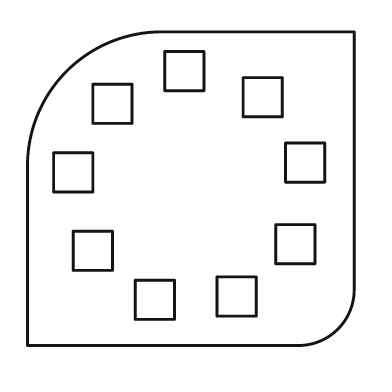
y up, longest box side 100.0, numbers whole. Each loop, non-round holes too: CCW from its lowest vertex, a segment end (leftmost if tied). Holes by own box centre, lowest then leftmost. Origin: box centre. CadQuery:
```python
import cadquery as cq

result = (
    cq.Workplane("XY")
    .moveTo(-50.0, -48.0)
    .lineTo(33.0, -48.0)
    .threePointArc((45.0, -43.0), (50.0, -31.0))
    .lineTo(50.0, 48.0)
    .lineTo(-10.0, 48.0)
    .threePointArc((-38.0, 36.0), (-50.0, 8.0))
    .close()
    .moveTo(-17.0, -40.0)
    .lineTo(-5.0, -40.0)
    .lineTo(-5.0, -28.0)
    .lineTo(-17.0, -28.0)
    .close()
    .moveTo(8.0, -39.0)
    .lineTo(20.0, -39.0)
    .lineTo(20.0, -27.0)
    .lineTo(8.0, -27.0)
    .close()
    .moveTo(-36.0, -25.0)
    .lineTo(-24.0, -25.0)
    .lineTo(-24.0, -13.0)
    .lineTo(-36.0, -13.0)
    .close()
    .moveTo(26.0, -23.0)
    .lineTo(38.0, -23.0)
    .lineTo(38.0, -11.0)
    .lineTo(26.0, -11.0)
    .close()
    .moveTo(-42.0, -1.0)
    .lineTo(-30.0, -1.0)
    .lineTo(-30.0, 11.0)
    .lineTo(-42.0, 11.0)
    .close()
    .moveTo(29.0, 2.0)
    .lineTo(41.0, 2.0)
    .lineTo(41.0, 14.0)
    .lineTo(29.0, 14.0)
    .close()
    .moveTo(-30.0, 20.0)
    .lineTo(-18.0, 20.0)
    .lineTo(-18.0, 32.0)
    .lineTo(-30.0, 32.0)
    .close()
    .moveTo(16.0, 22.0)
    .lineTo(28.0, 22.0)
    .lineTo(28.0, 34.0)
    .lineTo(16.0, 34.0)
    .close()
    .moveTo(-8.0, 30.0)
    .lineTo(4.0, 30.0)
    .lineTo(4.0, 42.0)
    .lineTo(-8.0, 42.0)
    .close()
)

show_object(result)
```